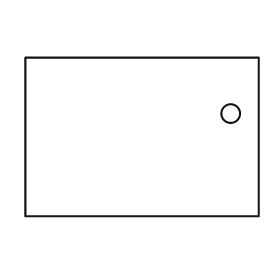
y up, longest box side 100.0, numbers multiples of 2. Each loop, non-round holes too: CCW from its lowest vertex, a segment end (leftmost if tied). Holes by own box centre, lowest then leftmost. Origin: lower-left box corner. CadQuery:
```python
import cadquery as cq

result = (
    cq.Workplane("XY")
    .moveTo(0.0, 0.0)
    .lineTo(100.0, 0.0)
    .lineTo(100.0, 68.0)
    .lineTo(0.0, 68.0)
    .close()
    .moveTo(88.0, 44.0)
    .circle(4.0)
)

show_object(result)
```